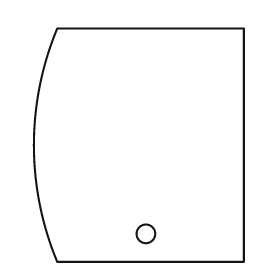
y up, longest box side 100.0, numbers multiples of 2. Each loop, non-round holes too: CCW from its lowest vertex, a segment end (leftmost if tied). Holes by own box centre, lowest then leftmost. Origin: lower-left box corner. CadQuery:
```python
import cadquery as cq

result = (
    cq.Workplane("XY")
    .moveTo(10.0, 0.0)
    .lineTo(90.0, 0.0)
    .lineTo(90.0, 100.0)
    .lineTo(10.0, 100.0)
    .threePointArc((0.0, 50.0), (10.0, 0.0))
    .close()
    .moveTo(48.0, 12.0)
    .circle(4.0)
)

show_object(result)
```